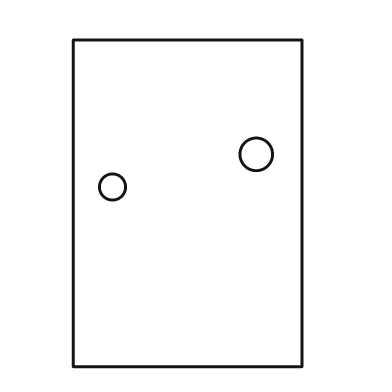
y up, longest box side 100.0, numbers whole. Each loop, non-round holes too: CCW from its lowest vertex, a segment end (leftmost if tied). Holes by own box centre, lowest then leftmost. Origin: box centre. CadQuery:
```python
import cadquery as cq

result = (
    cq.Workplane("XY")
    .moveTo(-35.0, -50.0)
    .lineTo(35.0, -50.0)
    .lineTo(35.0, 50.0)
    .lineTo(-35.0, 50.0)
    .close()
    .moveTo(-23.0, 5.0)
    .circle(4.0)
    .moveTo(21.0, 15.0)
    .circle(5.0)
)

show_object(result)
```